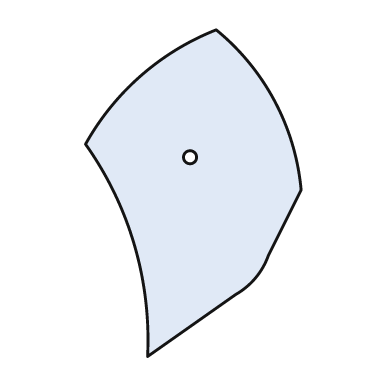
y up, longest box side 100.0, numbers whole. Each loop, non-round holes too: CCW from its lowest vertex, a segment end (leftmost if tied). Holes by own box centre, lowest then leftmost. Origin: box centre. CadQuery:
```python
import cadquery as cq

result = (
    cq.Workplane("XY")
    .moveTo(-14.0, -50.0)
    .lineTo(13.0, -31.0)
    .threePointArc((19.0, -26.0), (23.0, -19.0))
    .lineTo(33.0, 1.0)
    .threePointArc((25.0, 28.0), (7.0, 50.0))
    .threePointArc((-16.0, 36.0), (-33.0, 15.0))
    .threePointArc((-18.0, -16.0), (-14.0, -50.0))
    .close()
    .moveTo(-1.0, 11.0)
    .circle(2.0)
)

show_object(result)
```